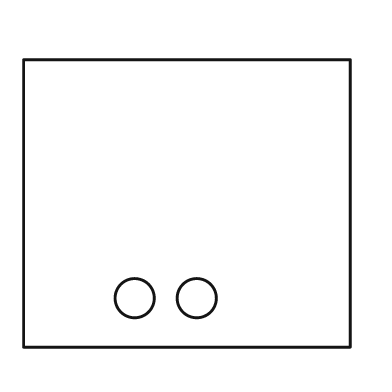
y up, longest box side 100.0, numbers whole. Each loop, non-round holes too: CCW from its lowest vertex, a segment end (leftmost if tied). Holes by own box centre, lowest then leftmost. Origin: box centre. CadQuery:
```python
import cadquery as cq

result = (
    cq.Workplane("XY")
    .moveTo(-50.0, -44.0)
    .lineTo(50.0, -44.0)
    .lineTo(50.0, 44.0)
    .lineTo(-50.0, 44.0)
    .close()
    .moveTo(-16.0, -29.0)
    .circle(6.0)
    .moveTo(3.0, -29.0)
    .circle(6.0)
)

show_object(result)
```